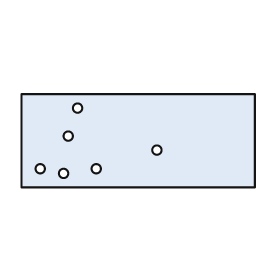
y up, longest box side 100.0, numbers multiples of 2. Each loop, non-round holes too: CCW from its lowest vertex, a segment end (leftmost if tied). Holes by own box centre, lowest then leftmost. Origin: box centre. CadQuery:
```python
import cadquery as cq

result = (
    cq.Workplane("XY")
    .moveTo(-50.0, -20.0)
    .lineTo(50.0, -20.0)
    .lineTo(50.0, 20.0)
    .lineTo(-50.0, 20.0)
    .close()
    .moveTo(-32.0, -14.0)
    .circle(2.0)
    .moveTo(-42.0, -12.0)
    .circle(2.0)
    .moveTo(-18.0, -12.0)
    .circle(2.0)
    .moveTo(8.0, -4.0)
    .circle(2.0)
    .moveTo(-30.0, 2.0)
    .circle(2.0)
    .moveTo(-26.0, 14.0)
    .circle(2.0)
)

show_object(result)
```